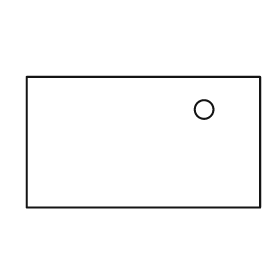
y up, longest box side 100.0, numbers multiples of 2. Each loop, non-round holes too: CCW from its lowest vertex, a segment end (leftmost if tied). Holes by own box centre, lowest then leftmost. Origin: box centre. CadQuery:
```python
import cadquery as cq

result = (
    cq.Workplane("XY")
    .moveTo(-50.0, -28.0)
    .lineTo(50.0, -28.0)
    .lineTo(50.0, 28.0)
    .lineTo(-50.0, 28.0)
    .close()
    .moveTo(26.0, 14.0)
    .circle(4.0)
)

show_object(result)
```